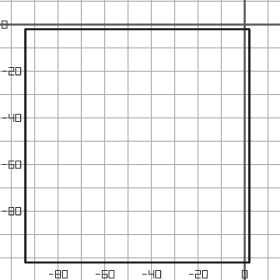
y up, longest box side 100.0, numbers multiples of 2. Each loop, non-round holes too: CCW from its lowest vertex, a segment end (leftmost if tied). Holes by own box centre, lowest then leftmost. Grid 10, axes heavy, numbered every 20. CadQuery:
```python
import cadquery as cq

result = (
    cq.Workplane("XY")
    .moveTo(-94.0, -102.0)
    .lineTo(2.0, -102.0)
    .lineTo(2.0, -2.0)
    .lineTo(-94.0, -2.0)
    .close()
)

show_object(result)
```